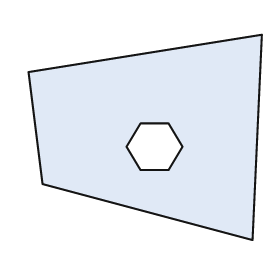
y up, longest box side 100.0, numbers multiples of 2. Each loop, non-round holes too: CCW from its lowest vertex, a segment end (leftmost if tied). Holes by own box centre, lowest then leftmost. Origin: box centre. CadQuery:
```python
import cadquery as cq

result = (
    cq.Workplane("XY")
    .moveTo(46.0, -44.0)
    .lineTo(50.0, 44.0)
    .lineTo(-50.0, 28.0)
    .lineTo(-44.0, -20.0)
    .close()
    .moveTo(-2.0, -14.0)
    .lineTo(10.0, -14.0)
    .lineTo(16.0, -4.0)
    .lineTo(10.0, 6.0)
    .lineTo(-2.0, 6.0)
    .lineTo(-8.0, -4.0)
    .close()
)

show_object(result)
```